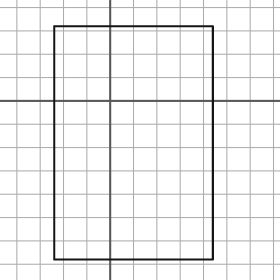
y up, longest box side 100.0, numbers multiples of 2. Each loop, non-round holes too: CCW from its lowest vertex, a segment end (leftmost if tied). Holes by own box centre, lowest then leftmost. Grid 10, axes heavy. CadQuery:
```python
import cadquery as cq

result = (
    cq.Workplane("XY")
    .moveTo(-24.0, -68.0)
    .lineTo(44.0, -68.0)
    .lineTo(44.0, 32.0)
    .lineTo(-24.0, 32.0)
    .close()
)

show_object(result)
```